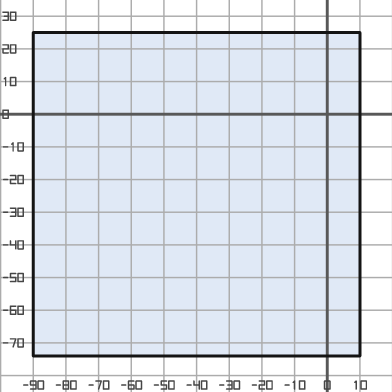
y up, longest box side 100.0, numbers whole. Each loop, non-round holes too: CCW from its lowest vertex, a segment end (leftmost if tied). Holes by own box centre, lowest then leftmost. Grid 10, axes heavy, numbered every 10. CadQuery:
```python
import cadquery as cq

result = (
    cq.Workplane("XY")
    .moveTo(-90.0, -74.0)
    .lineTo(10.0, -74.0)
    .lineTo(10.0, 25.0)
    .lineTo(-90.0, 25.0)
    .close()
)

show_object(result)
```